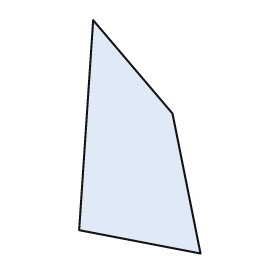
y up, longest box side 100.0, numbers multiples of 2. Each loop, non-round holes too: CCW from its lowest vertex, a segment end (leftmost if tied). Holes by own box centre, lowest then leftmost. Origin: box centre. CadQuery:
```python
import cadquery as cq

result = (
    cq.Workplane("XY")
    .moveTo(26.0, -50.0)
    .lineTo(14.0, 10.0)
    .lineTo(-20.0, 50.0)
    .lineTo(-26.0, -40.0)
    .close()
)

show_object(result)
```